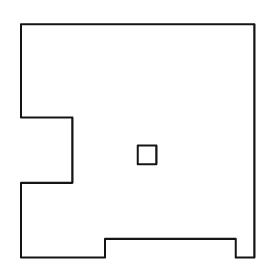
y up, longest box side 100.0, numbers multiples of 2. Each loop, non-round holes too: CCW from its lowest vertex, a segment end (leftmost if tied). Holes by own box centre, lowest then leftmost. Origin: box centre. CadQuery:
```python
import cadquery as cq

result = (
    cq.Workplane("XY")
    .moveTo(-50.0, -50.0)
    .lineTo(-14.0, -50.0)
    .lineTo(-14.0, -42.0)
    .lineTo(42.0, -42.0)
    .lineTo(42.0, -50.0)
    .lineTo(50.0, -50.0)
    .lineTo(50.0, 50.0)
    .lineTo(-50.0, 50.0)
    .lineTo(-50.0, 10.0)
    .lineTo(-28.0, 10.0)
    .lineTo(-28.0, -18.0)
    .lineTo(-50.0, -18.0)
    .close()
    .moveTo(0.0, -10.0)
    .lineTo(8.0, -10.0)
    .lineTo(8.0, -2.0)
    .lineTo(0.0, -2.0)
    .close()
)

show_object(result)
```